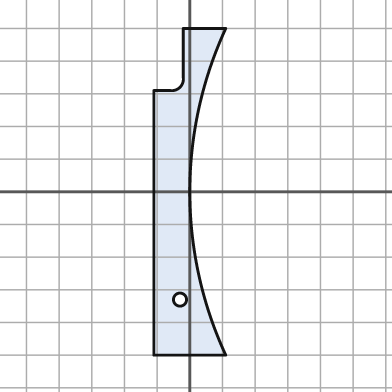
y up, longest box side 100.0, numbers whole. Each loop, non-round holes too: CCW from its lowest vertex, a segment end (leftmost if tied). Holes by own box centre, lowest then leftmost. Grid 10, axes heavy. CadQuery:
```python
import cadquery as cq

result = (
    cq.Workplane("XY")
    .moveTo(-11.0, -50.0)
    .lineTo(11.0, -50.0)
    .threePointArc((0.0, 0.0), (11.0, 50.0))
    .lineTo(-2.0, 50.0)
    .lineTo(-2.0, 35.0)
    .threePointArc((-3.0, 32.0), (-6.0, 31.0))
    .lineTo(-11.0, 31.0)
    .close()
    .moveTo(-3.0, -33.0)
    .circle(2.0)
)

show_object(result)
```